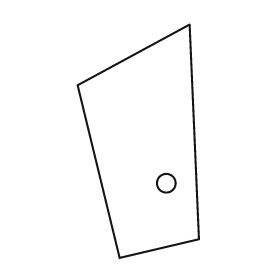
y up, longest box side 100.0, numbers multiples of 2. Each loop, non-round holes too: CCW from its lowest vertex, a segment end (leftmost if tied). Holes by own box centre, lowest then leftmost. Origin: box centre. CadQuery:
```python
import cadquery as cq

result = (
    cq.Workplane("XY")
    .moveTo(-8.0, -50.0)
    .lineTo(26.0, -42.0)
    .lineTo(22.0, 50.0)
    .lineTo(-26.0, 24.0)
    .close()
    .moveTo(12.0, -18.0)
    .circle(4.0)
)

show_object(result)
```